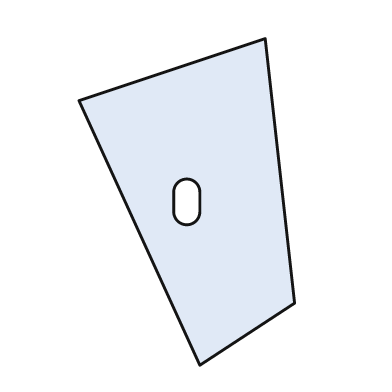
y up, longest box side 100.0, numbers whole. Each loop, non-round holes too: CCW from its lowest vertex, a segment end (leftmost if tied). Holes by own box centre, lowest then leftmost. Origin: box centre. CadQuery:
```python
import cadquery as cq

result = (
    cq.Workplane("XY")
    .moveTo(4.0, -50.0)
    .lineTo(33.0, -31.0)
    .lineTo(24.0, 50.0)
    .lineTo(-33.0, 31.0)
    .close()
    .moveTo(-4.0, -3.0)
    .threePointArc((0.0, -7.0), (4.0, -3.0))
    .lineTo(4.0, 3.0)
    .threePointArc((0.0, 7.0), (-4.0, 3.0))
    .close()
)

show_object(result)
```